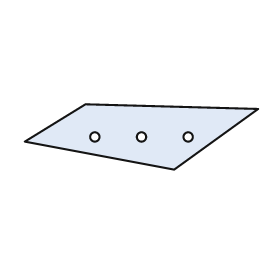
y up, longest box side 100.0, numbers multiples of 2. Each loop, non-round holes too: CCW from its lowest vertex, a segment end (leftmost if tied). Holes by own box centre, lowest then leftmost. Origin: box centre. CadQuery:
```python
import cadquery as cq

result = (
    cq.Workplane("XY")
    .moveTo(14.0, -14.0)
    .lineTo(50.0, 12.0)
    .lineTo(-24.0, 14.0)
    .lineTo(-50.0, -2.0)
    .close()
    .moveTo(-20.0, 0.0)
    .circle(2.0)
    .moveTo(0.0, 0.0)
    .circle(2.0)
    .moveTo(20.0, 0.0)
    .circle(2.0)
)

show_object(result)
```